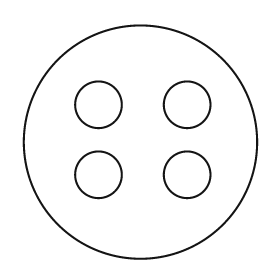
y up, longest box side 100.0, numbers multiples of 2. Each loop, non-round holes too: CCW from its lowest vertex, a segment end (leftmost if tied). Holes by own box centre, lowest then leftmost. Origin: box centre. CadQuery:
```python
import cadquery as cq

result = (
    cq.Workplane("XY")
    .moveTo(0.0, 0.0)
    .circle(50.0)
    .moveTo(-18.0, -14.0)
    .circle(10.0)
    .moveTo(20.0, -14.0)
    .circle(10.0)
    .moveTo(-18.0, 16.0)
    .circle(10.0)
    .moveTo(20.0, 16.0)
    .circle(10.0)
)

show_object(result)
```